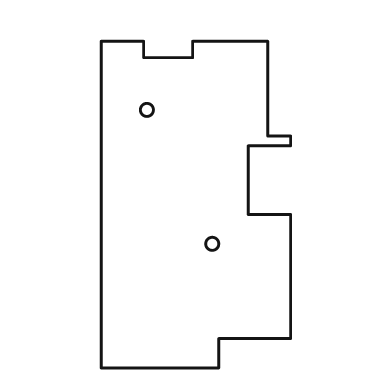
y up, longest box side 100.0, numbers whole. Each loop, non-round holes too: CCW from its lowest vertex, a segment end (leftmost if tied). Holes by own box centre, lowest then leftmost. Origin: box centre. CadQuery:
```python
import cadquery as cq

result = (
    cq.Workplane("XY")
    .moveTo(-29.0, -50.0)
    .lineTo(7.0, -50.0)
    .lineTo(7.0, -41.0)
    .lineTo(29.0, -41.0)
    .lineTo(29.0, -3.0)
    .lineTo(16.0, -3.0)
    .lineTo(16.0, 18.0)
    .lineTo(29.0, 18.0)
    .lineTo(29.0, 21.0)
    .lineTo(22.0, 21.0)
    .lineTo(22.0, 50.0)
    .lineTo(-1.0, 50.0)
    .lineTo(-1.0, 45.0)
    .lineTo(-16.0, 45.0)
    .lineTo(-16.0, 50.0)
    .lineTo(-29.0, 50.0)
    .close()
    .moveTo(5.0, -12.0)
    .circle(2.0)
    .moveTo(-15.0, 29.0)
    .circle(2.0)
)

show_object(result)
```